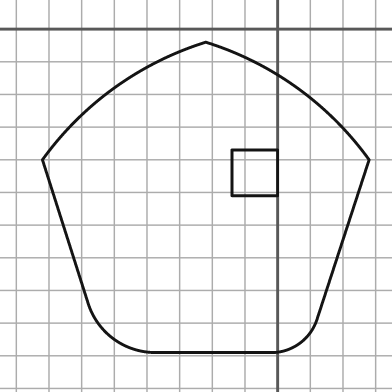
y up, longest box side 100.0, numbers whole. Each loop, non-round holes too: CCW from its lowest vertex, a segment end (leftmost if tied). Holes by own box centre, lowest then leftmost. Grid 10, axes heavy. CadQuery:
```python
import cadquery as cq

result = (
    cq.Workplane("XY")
    .moveTo(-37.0, -99.0)
    .lineTo(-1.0, -99.0)
    .threePointArc((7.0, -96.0), (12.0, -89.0))
    .lineTo(28.0, -40.0)
    .threePointArc((6.0, -18.0), (-22.0, -4.0))
    .threePointArc((-50.0, -18.0), (-72.0, -40.0))
    .lineTo(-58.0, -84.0)
    .threePointArc((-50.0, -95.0), (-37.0, -99.0))
    .close()
    .moveTo(-14.0, -51.0)
    .lineTo(0.0, -51.0)
    .lineTo(0.0, -37.0)
    .lineTo(-14.0, -37.0)
    .close()
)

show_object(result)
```